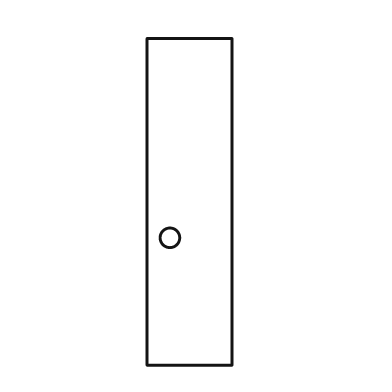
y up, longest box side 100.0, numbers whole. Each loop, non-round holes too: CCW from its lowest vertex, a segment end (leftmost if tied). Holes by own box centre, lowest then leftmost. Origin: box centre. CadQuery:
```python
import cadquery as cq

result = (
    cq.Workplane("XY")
    .moveTo(-13.0, -50.0)
    .lineTo(13.0, -50.0)
    .lineTo(13.0, 50.0)
    .lineTo(-13.0, 50.0)
    .close()
    .moveTo(-6.0, -11.0)
    .circle(3.0)
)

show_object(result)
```